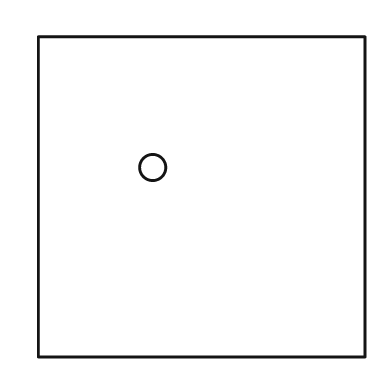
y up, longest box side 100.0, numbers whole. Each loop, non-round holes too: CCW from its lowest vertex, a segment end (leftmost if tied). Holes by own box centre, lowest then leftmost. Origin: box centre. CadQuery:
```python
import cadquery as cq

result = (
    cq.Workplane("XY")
    .moveTo(-50.0, -49.0)
    .lineTo(50.0, -49.0)
    .lineTo(50.0, 49.0)
    .lineTo(-50.0, 49.0)
    .close()
    .moveTo(-15.0, 9.0)
    .circle(4.0)
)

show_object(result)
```